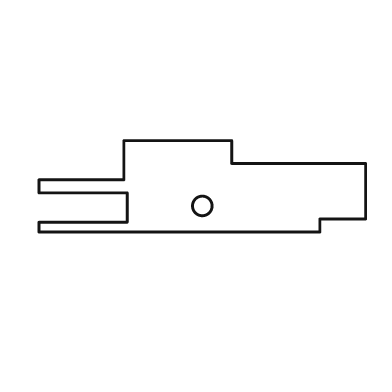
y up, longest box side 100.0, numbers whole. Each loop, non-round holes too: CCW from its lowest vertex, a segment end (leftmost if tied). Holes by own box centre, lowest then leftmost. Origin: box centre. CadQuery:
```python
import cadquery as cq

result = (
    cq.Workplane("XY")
    .moveTo(-50.0, -14.0)
    .lineTo(36.0, -14.0)
    .lineTo(36.0, -10.0)
    .lineTo(50.0, -10.0)
    .lineTo(50.0, 7.0)
    .lineTo(9.0, 7.0)
    .lineTo(9.0, 14.0)
    .lineTo(-24.0, 14.0)
    .lineTo(-24.0, 2.0)
    .lineTo(-50.0, 2.0)
    .lineTo(-50.0, -2.0)
    .lineTo(-23.0, -2.0)
    .lineTo(-23.0, -11.0)
    .lineTo(-50.0, -11.0)
    .close()
    .moveTo(0.0, -6.0)
    .circle(3.0)
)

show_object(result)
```